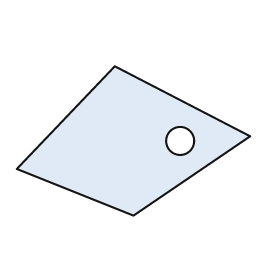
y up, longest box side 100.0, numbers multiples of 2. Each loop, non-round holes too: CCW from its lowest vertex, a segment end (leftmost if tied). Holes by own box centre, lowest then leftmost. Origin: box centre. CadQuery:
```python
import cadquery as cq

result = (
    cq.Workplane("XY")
    .moveTo(0.0, -32.0)
    .lineTo(50.0, 2.0)
    .lineTo(-8.0, 32.0)
    .lineTo(-50.0, -12.0)
    .close()
    .moveTo(20.0, 0.0)
    .circle(6.0)
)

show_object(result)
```